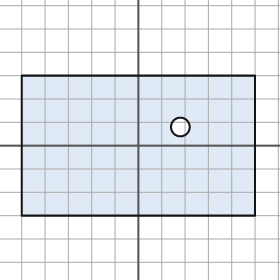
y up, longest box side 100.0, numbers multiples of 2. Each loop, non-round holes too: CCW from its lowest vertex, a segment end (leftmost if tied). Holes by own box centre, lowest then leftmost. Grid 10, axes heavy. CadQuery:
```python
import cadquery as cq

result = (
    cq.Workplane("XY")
    .moveTo(-50.0, -30.0)
    .lineTo(50.0, -30.0)
    .lineTo(50.0, 30.0)
    .lineTo(-50.0, 30.0)
    .close()
    .moveTo(18.0, 8.0)
    .circle(4.0)
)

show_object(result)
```